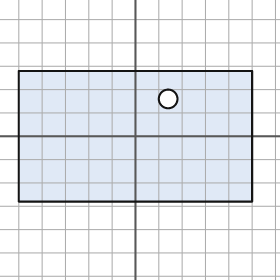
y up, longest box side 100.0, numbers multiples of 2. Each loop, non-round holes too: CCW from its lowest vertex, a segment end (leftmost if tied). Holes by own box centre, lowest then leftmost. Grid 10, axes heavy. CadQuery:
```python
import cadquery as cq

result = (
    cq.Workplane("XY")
    .moveTo(-50.0, -28.0)
    .lineTo(50.0, -28.0)
    .lineTo(50.0, 28.0)
    .lineTo(-50.0, 28.0)
    .close()
    .moveTo(14.0, 16.0)
    .circle(4.0)
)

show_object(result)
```